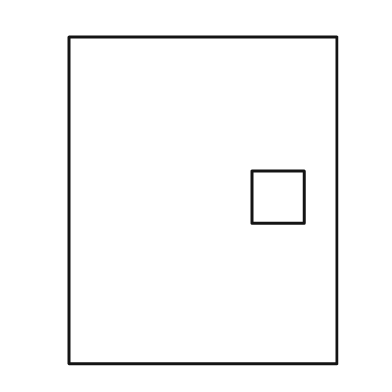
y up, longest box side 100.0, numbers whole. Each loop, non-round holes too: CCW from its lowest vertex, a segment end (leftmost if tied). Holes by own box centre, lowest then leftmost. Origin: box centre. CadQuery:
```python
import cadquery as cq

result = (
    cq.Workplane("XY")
    .moveTo(-41.0, -50.0)
    .lineTo(41.0, -50.0)
    .lineTo(41.0, 50.0)
    .lineTo(-41.0, 50.0)
    .close()
    .moveTo(15.0, -7.0)
    .lineTo(31.0, -7.0)
    .lineTo(31.0, 9.0)
    .lineTo(15.0, 9.0)
    .close()
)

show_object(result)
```